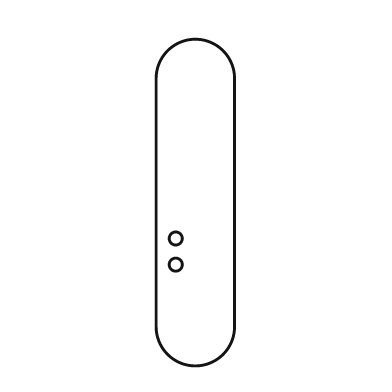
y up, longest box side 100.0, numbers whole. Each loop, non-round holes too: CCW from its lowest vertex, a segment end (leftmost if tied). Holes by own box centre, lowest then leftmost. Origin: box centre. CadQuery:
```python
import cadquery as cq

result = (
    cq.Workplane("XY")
    .moveTo(-12.0, -38.0)
    .threePointArc((0.0, -50.0), (12.0, -38.0))
    .lineTo(12.0, 38.0)
    .threePointArc((0.0, 50.0), (-12.0, 38.0))
    .close()
    .moveTo(-6.0, -19.0)
    .circle(2.0)
    .moveTo(-6.0, -11.0)
    .circle(2.0)
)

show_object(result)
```